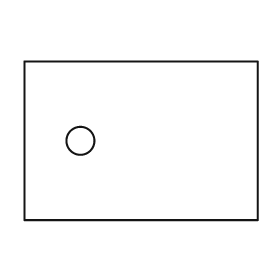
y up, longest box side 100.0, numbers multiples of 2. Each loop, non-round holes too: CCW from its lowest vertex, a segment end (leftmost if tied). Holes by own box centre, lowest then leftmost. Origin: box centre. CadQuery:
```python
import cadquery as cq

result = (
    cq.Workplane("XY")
    .moveTo(-50.0, -34.0)
    .lineTo(50.0, -34.0)
    .lineTo(50.0, 34.0)
    .lineTo(-50.0, 34.0)
    .close()
    .moveTo(-26.0, 0.0)
    .circle(6.0)
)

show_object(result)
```